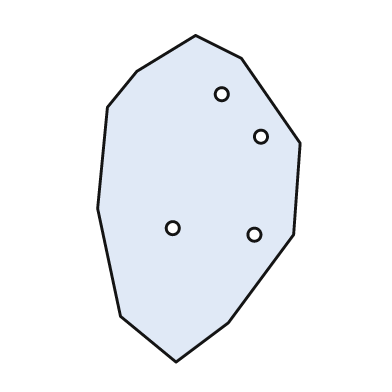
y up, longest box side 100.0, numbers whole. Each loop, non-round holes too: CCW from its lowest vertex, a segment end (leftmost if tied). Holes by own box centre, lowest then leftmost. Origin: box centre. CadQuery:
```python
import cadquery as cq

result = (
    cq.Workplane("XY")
    .moveTo(-7.0, -50.0)
    .lineTo(9.0, -38.0)
    .lineTo(29.0, -11.0)
    .lineTo(31.0, 17.0)
    .lineTo(13.0, 43.0)
    .lineTo(-1.0, 50.0)
    .lineTo(-19.0, 39.0)
    .lineTo(-28.0, 28.0)
    .lineTo(-31.0, -3.0)
    .lineTo(-24.0, -36.0)
    .close()
    .moveTo(17.0, -11.0)
    .circle(2.0)
    .moveTo(-8.0, -9.0)
    .circle(2.0)
    .moveTo(19.0, 19.0)
    .circle(2.0)
    .moveTo(7.0, 32.0)
    .circle(2.0)
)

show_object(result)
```